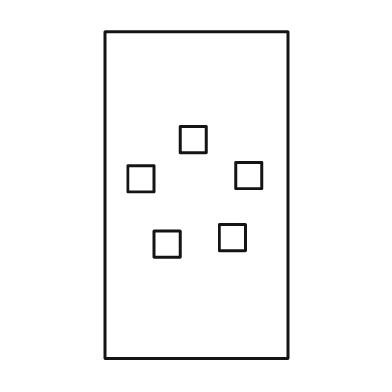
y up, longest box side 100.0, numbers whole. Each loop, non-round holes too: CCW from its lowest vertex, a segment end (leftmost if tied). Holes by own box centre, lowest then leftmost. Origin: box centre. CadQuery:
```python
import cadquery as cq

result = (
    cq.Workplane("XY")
    .moveTo(-28.0, -50.0)
    .lineTo(28.0, -50.0)
    .lineTo(28.0, 50.0)
    .lineTo(-28.0, 50.0)
    .close()
    .moveTo(-13.0, -19.0)
    .lineTo(-5.0, -19.0)
    .lineTo(-5.0, -11.0)
    .lineTo(-13.0, -11.0)
    .close()
    .moveTo(7.0, -17.0)
    .lineTo(15.0, -17.0)
    .lineTo(15.0, -9.0)
    .lineTo(7.0, -9.0)
    .close()
    .moveTo(-21.0, 1.0)
    .lineTo(-13.0, 1.0)
    .lineTo(-13.0, 9.0)
    .lineTo(-21.0, 9.0)
    .close()
    .moveTo(12.0, 2.0)
    .lineTo(20.0, 2.0)
    .lineTo(20.0, 10.0)
    .lineTo(12.0, 10.0)
    .close()
    .moveTo(-5.0, 13.0)
    .lineTo(3.0, 13.0)
    .lineTo(3.0, 21.0)
    .lineTo(-5.0, 21.0)
    .close()
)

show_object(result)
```